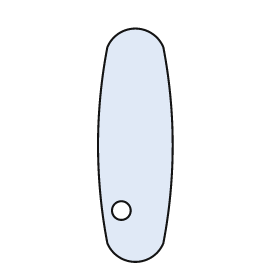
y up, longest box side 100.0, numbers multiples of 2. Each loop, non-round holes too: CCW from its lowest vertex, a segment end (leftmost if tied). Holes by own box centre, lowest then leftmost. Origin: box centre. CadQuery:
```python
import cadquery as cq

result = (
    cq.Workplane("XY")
    .moveTo(-12.0, -42.0)
    .threePointArc((0.0, -50.0), (12.0, -42.0))
    .threePointArc((16.0, 0.0), (12.0, 42.0))
    .threePointArc((0.0, 50.0), (-12.0, 42.0))
    .threePointArc((-16.0, 0.0), (-12.0, -42.0))
    .close()
    .moveTo(-6.0, -28.0)
    .circle(4.0)
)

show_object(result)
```